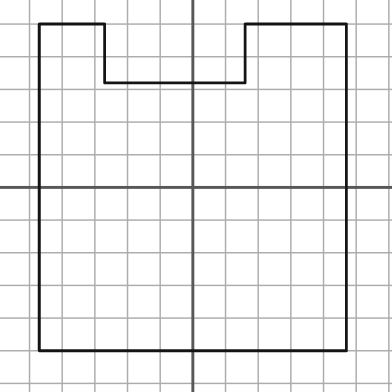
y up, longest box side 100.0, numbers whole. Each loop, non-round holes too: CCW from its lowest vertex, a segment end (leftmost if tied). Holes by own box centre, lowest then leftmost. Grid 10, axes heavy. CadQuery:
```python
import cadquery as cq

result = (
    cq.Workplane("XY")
    .moveTo(-47.0, -50.0)
    .lineTo(47.0, -50.0)
    .lineTo(47.0, 50.0)
    .lineTo(16.0, 50.0)
    .lineTo(16.0, 32.0)
    .lineTo(-27.0, 32.0)
    .lineTo(-27.0, 50.0)
    .lineTo(-47.0, 50.0)
    .close()
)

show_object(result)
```